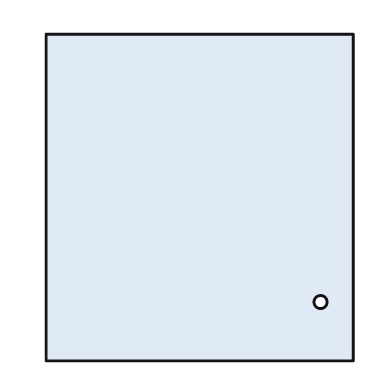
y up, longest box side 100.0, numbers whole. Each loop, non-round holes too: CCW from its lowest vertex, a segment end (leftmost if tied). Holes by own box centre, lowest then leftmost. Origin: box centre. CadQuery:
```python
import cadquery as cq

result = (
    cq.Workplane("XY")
    .moveTo(-47.0, -50.0)
    .lineTo(47.0, -50.0)
    .lineTo(47.0, 50.0)
    .lineTo(-47.0, 50.0)
    .close()
    .moveTo(37.0, -32.0)
    .circle(2.0)
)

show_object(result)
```